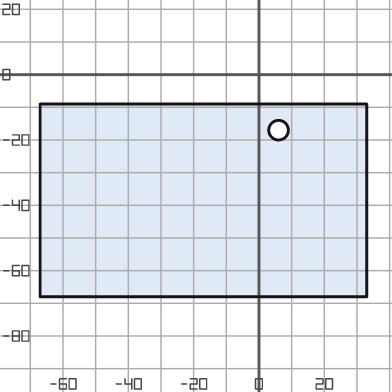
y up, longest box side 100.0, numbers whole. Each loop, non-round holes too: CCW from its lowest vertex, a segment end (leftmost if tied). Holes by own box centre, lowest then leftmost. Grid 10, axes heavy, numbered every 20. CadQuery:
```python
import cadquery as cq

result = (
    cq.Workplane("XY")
    .moveTo(-67.0, -68.0)
    .lineTo(33.0, -68.0)
    .lineTo(33.0, -9.0)
    .lineTo(-67.0, -9.0)
    .close()
    .moveTo(6.0, -17.0)
    .circle(3.0)
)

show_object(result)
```